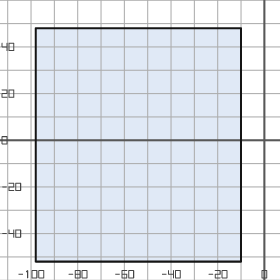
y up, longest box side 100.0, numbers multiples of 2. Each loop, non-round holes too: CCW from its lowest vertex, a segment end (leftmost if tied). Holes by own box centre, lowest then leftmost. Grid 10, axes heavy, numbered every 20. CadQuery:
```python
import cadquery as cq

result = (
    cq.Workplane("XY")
    .moveTo(-98.0, -52.0)
    .lineTo(-10.0, -52.0)
    .lineTo(-10.0, 48.0)
    .lineTo(-98.0, 48.0)
    .close()
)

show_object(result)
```